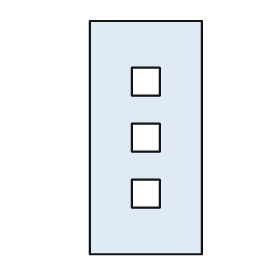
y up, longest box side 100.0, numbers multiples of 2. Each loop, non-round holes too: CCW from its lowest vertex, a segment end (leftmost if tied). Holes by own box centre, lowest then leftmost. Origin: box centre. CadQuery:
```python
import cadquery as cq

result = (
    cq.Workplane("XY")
    .moveTo(-24.0, -50.0)
    .lineTo(24.0, -50.0)
    .lineTo(24.0, 50.0)
    .lineTo(-24.0, 50.0)
    .close()
    .moveTo(-6.0, -30.0)
    .lineTo(6.0, -30.0)
    .lineTo(6.0, -18.0)
    .lineTo(-6.0, -18.0)
    .close()
    .moveTo(-6.0, -6.0)
    .lineTo(6.0, -6.0)
    .lineTo(6.0, 6.0)
    .lineTo(-6.0, 6.0)
    .close()
    .moveTo(-6.0, 18.0)
    .lineTo(6.0, 18.0)
    .lineTo(6.0, 30.0)
    .lineTo(-6.0, 30.0)
    .close()
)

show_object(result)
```